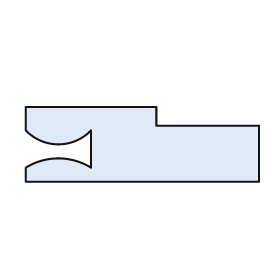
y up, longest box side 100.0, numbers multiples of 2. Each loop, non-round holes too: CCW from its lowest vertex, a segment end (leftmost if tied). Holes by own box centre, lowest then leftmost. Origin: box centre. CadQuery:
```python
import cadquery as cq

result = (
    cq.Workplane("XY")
    .moveTo(-50.0, -16.0)
    .lineTo(50.0, -16.0)
    .lineTo(50.0, 8.0)
    .lineTo(6.0, 8.0)
    .lineTo(6.0, 16.0)
    .lineTo(-50.0, 16.0)
    .lineTo(-50.0, 6.0)
    .threePointArc((-36.0, 0.0), (-22.0, 6.0))
    .lineTo(-22.0, -10.0)
    .threePointArc((-36.0, -6.0), (-50.0, -10.0))
    .close()
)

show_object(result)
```